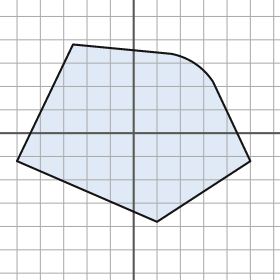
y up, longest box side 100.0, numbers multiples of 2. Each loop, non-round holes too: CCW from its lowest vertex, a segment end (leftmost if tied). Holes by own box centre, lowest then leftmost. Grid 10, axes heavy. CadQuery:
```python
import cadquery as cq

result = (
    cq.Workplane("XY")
    .moveTo(10.0, -38.0)
    .lineTo(50.0, -12.0)
    .lineTo(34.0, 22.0)
    .threePointArc((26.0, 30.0), (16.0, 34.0))
    .lineTo(-26.0, 38.0)
    .lineTo(-50.0, -12.0)
    .close()
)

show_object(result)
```